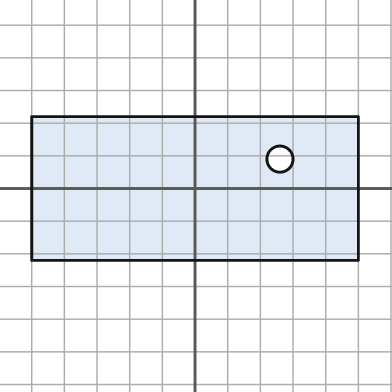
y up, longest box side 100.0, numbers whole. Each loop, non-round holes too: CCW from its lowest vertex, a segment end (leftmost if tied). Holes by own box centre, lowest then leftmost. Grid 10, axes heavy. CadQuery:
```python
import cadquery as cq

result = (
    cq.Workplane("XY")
    .moveTo(-50.0, -22.0)
    .lineTo(50.0, -22.0)
    .lineTo(50.0, 22.0)
    .lineTo(-50.0, 22.0)
    .close()
    .moveTo(26.0, 9.0)
    .circle(4.0)
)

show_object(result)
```